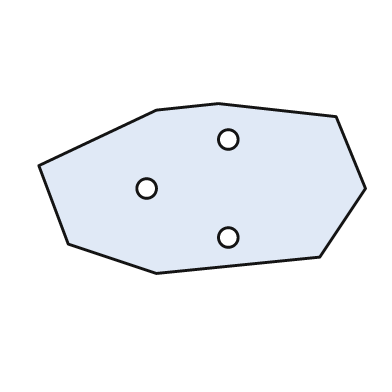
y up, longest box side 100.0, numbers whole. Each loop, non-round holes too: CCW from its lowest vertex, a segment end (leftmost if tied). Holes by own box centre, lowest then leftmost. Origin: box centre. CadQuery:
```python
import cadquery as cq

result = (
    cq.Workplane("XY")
    .moveTo(-14.0, -26.0)
    .lineTo(36.0, -21.0)
    .lineTo(50.0, 0.0)
    .lineTo(41.0, 22.0)
    .lineTo(5.0, 26.0)
    .lineTo(-14.0, 24.0)
    .lineTo(-50.0, 7.0)
    .lineTo(-41.0, -17.0)
    .close()
    .moveTo(8.0, -15.0)
    .circle(3.0)
    .moveTo(-17.0, 0.0)
    .circle(3.0)
    .moveTo(8.0, 15.0)
    .circle(3.0)
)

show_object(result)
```